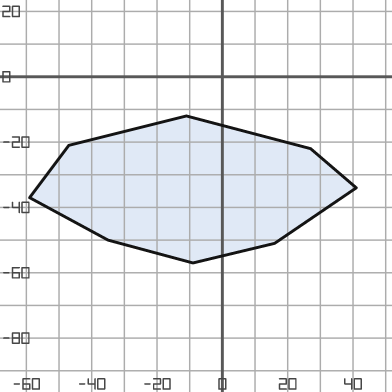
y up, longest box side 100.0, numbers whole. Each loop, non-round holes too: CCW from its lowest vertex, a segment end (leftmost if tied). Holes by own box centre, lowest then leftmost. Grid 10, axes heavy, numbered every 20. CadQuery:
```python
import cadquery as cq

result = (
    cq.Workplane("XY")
    .moveTo(-9.0, -57.0)
    .lineTo(16.0, -51.0)
    .lineTo(41.0, -34.0)
    .lineTo(27.0, -22.0)
    .lineTo(-11.0, -12.0)
    .lineTo(-47.0, -21.0)
    .lineTo(-59.0, -37.0)
    .lineTo(-35.0, -50.0)
    .close()
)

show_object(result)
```